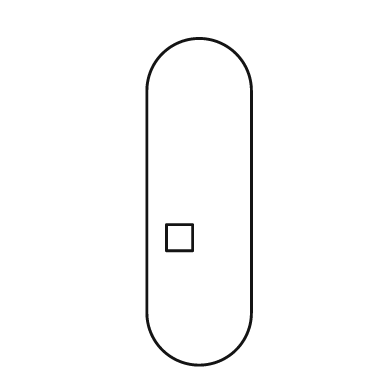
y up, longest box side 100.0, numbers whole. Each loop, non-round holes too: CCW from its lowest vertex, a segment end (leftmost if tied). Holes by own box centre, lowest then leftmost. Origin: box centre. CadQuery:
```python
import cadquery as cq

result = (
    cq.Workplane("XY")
    .moveTo(-16.0, -34.0)
    .threePointArc((0.0, -50.0), (16.0, -34.0))
    .lineTo(16.0, 34.0)
    .threePointArc((0.0, 50.0), (-16.0, 34.0))
    .close()
    .moveTo(-10.0, -15.0)
    .lineTo(-2.0, -15.0)
    .lineTo(-2.0, -7.0)
    .lineTo(-10.0, -7.0)
    .close()
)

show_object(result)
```